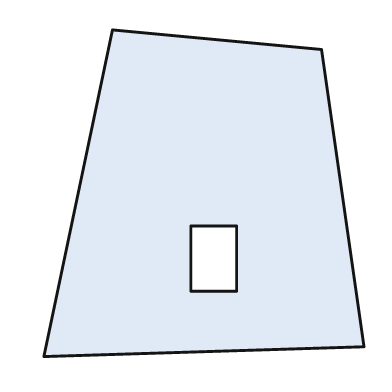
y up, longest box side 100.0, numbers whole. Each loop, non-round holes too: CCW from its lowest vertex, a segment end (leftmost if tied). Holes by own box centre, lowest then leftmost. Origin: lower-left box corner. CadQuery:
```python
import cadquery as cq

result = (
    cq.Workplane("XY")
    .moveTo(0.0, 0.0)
    .lineTo(98.0, 3.0)
    .lineTo(85.0, 94.0)
    .lineTo(21.0, 100.0)
    .close()
    .moveTo(45.0, 20.0)
    .lineTo(59.0, 20.0)
    .lineTo(59.0, 40.0)
    .lineTo(45.0, 40.0)
    .close()
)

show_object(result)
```